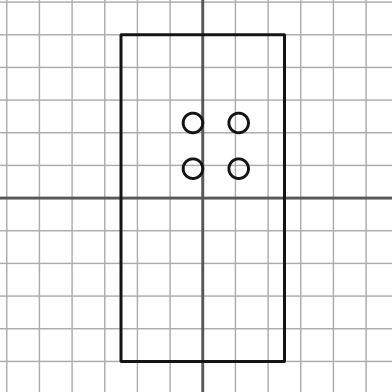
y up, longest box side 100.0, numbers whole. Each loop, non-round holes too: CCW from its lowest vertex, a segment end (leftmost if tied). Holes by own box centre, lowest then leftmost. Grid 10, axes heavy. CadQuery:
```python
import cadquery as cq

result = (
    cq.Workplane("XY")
    .moveTo(-25.0, -50.0)
    .lineTo(25.0, -50.0)
    .lineTo(25.0, 50.0)
    .lineTo(-25.0, 50.0)
    .close()
    .moveTo(-3.0, 9.0)
    .circle(3.0)
    .moveTo(11.0, 9.0)
    .circle(3.0)
    .moveTo(-3.0, 23.0)
    .circle(3.0)
    .moveTo(11.0, 23.0)
    .circle(3.0)
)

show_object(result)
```